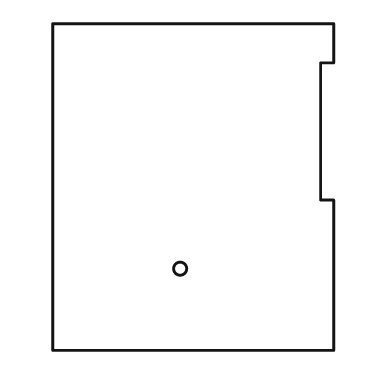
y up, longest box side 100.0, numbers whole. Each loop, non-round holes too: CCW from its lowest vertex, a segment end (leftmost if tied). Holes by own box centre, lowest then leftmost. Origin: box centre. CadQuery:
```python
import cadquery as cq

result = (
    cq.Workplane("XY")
    .moveTo(-43.0, -50.0)
    .lineTo(43.0, -50.0)
    .lineTo(43.0, -4.0)
    .lineTo(39.0, -4.0)
    .lineTo(39.0, 38.0)
    .lineTo(43.0, 38.0)
    .lineTo(43.0, 50.0)
    .lineTo(-43.0, 50.0)
    .close()
    .moveTo(-4.0, -25.0)
    .circle(2.0)
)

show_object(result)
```